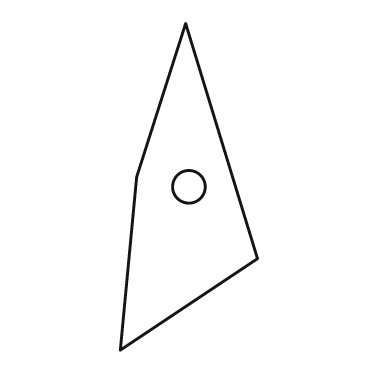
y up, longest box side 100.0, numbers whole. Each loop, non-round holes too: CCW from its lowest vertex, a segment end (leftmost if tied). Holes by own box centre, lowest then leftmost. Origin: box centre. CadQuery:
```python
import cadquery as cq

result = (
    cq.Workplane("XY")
    .moveTo(-21.0, -50.0)
    .lineTo(21.0, -22.0)
    .lineTo(-1.0, 50.0)
    .lineTo(-16.0, 3.0)
    .close()
    .moveTo(0.0, 0.0)
    .circle(5.0)
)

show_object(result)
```